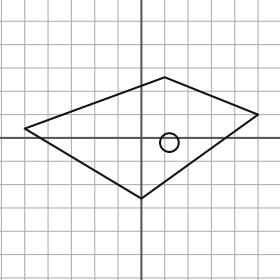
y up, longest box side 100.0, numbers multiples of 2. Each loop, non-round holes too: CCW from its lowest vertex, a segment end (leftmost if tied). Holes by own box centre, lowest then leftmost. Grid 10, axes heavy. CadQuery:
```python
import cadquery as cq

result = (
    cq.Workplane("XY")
    .moveTo(0.0, -26.0)
    .lineTo(50.0, 10.0)
    .lineTo(10.0, 26.0)
    .lineTo(-50.0, 4.0)
    .close()
    .moveTo(12.0, -2.0)
    .circle(4.0)
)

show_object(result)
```